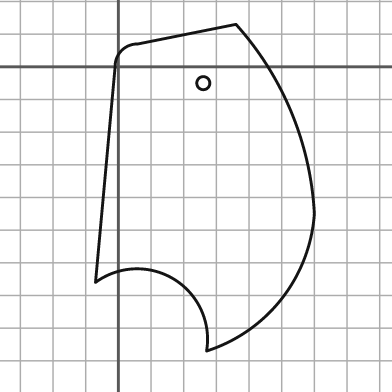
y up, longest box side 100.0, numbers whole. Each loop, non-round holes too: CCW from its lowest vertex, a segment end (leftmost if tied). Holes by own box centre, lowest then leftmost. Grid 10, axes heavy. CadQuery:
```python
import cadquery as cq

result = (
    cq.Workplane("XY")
    .moveTo(27.0, -87.0)
    .threePointArc((50.0, -71.0), (60.0, -45.0))
    .threePointArc((53.0, -14.0), (36.0, 13.0))
    .lineTo(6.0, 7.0)
    .threePointArc((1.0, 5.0), (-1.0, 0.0))
    .lineTo(-7.0, -66.0)
    .threePointArc((17.0, -65.0), (27.0, -87.0))
    .close()
    .moveTo(26.0, -5.0)
    .circle(2.0)
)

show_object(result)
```